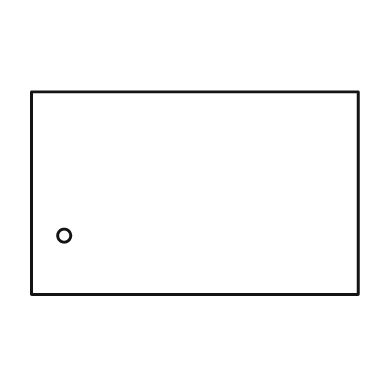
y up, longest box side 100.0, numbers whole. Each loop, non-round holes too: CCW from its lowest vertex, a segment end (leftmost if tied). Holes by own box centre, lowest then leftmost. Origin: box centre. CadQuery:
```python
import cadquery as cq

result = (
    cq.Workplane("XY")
    .moveTo(-50.0, -31.0)
    .lineTo(50.0, -31.0)
    .lineTo(50.0, 31.0)
    .lineTo(-50.0, 31.0)
    .close()
    .moveTo(-40.0, -13.0)
    .circle(2.0)
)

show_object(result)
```